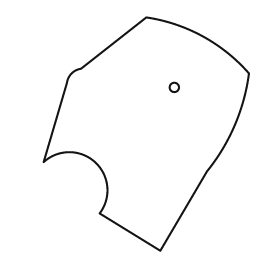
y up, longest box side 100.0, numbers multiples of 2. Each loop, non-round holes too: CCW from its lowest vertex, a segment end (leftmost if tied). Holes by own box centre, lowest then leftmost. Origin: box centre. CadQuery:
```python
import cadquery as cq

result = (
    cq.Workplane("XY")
    .moveTo(6.0, -50.0)
    .lineTo(26.0, -16.0)
    .threePointArc((38.0, 4.0), (44.0, 26.0))
    .threePointArc((24.0, 42.0), (0.0, 50.0))
    .lineTo(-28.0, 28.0)
    .threePointArc((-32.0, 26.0), (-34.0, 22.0))
    .lineTo(-44.0, -12.0)
    .threePointArc((-22.0, -12.0), (-20.0, -34.0))
    .close()
    .moveTo(12.0, 20.0)
    .circle(2.0)
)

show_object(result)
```